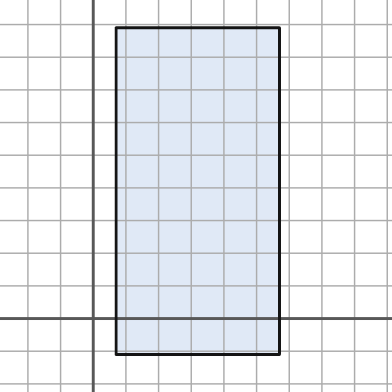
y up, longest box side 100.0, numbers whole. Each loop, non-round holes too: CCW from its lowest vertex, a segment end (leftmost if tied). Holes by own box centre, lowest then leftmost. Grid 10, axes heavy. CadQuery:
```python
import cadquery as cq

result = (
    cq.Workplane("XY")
    .moveTo(7.0, -11.0)
    .lineTo(57.0, -11.0)
    .lineTo(57.0, 89.0)
    .lineTo(7.0, 89.0)
    .close()
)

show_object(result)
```